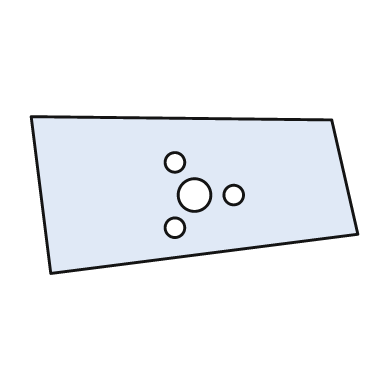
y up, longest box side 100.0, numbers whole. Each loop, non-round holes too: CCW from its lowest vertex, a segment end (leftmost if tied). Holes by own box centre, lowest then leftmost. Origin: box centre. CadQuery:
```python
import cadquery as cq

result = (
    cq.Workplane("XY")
    .moveTo(-44.0, -24.0)
    .lineTo(50.0, -12.0)
    .lineTo(42.0, 23.0)
    .lineTo(-50.0, 24.0)
    .close()
    .moveTo(-6.0, -10.0)
    .circle(3.0)
    .moveTo(0.0, 0.0)
    .circle(5.0)
    .moveTo(12.0, 0.0)
    .circle(3.0)
    .moveTo(-6.0, 10.0)
    .circle(3.0)
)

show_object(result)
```